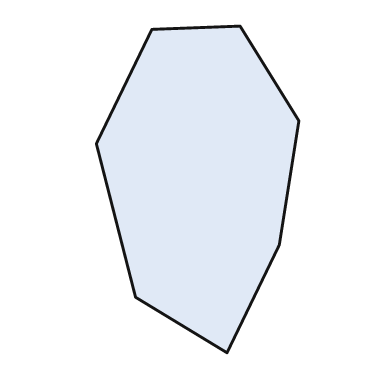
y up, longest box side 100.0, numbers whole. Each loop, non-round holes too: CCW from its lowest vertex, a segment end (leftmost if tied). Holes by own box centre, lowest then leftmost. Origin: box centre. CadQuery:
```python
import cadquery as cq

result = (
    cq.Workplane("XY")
    .moveTo(9.0, -50.0)
    .lineTo(25.0, -17.0)
    .lineTo(31.0, 21.0)
    .lineTo(13.0, 50.0)
    .lineTo(-14.0, 49.0)
    .lineTo(-31.0, 14.0)
    .lineTo(-19.0, -33.0)
    .close()
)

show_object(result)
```